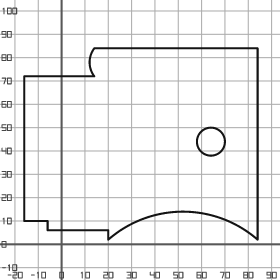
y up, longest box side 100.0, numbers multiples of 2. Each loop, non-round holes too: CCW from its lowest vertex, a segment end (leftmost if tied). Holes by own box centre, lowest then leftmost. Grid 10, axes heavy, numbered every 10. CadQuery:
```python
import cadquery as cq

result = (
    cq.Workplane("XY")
    .moveTo(20.0, 2.0)
    .threePointArc((52.0, 14.0), (84.0, 2.0))
    .lineTo(84.0, 84.0)
    .lineTo(14.0, 84.0)
    .threePointArc((12.0, 78.0), (14.0, 72.0))
    .lineTo(-16.0, 72.0)
    .lineTo(-16.0, 10.0)
    .lineTo(-6.0, 10.0)
    .lineTo(-6.0, 6.0)
    .lineTo(20.0, 6.0)
    .close()
    .moveTo(64.0, 44.0)
    .circle(6.0)
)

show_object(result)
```